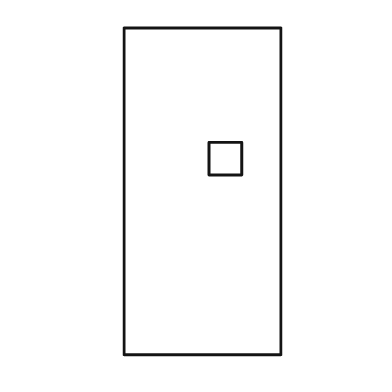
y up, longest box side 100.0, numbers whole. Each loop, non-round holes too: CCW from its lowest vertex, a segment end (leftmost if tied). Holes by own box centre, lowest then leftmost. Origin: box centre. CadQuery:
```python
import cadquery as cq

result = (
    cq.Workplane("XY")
    .moveTo(-24.0, -50.0)
    .lineTo(24.0, -50.0)
    .lineTo(24.0, 50.0)
    .lineTo(-24.0, 50.0)
    .close()
    .moveTo(2.0, 5.0)
    .lineTo(12.0, 5.0)
    .lineTo(12.0, 15.0)
    .lineTo(2.0, 15.0)
    .close()
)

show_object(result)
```